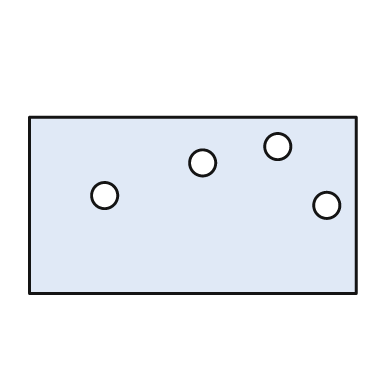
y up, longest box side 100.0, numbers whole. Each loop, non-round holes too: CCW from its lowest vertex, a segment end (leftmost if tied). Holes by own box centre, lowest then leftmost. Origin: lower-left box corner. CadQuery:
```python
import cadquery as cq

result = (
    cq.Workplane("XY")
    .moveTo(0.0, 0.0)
    .lineTo(100.0, 0.0)
    .lineTo(100.0, 54.0)
    .lineTo(0.0, 54.0)
    .close()
    .moveTo(91.0, 27.0)
    .circle(4.0)
    .moveTo(23.0, 30.0)
    .circle(4.0)
    .moveTo(53.0, 40.0)
    .circle(4.0)
    .moveTo(76.0, 45.0)
    .circle(4.0)
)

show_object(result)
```